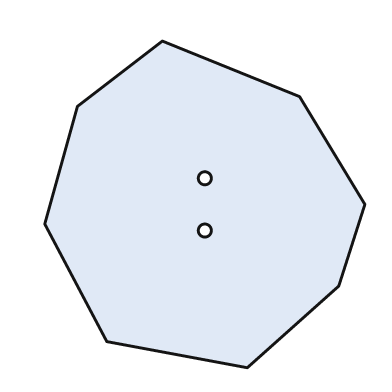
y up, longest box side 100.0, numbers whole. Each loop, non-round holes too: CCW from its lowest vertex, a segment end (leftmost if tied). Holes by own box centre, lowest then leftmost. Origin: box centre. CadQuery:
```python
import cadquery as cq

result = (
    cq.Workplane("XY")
    .moveTo(13.0, -50.0)
    .lineTo(41.0, -25.0)
    .lineTo(49.0, 0.0)
    .lineTo(29.0, 33.0)
    .lineTo(-13.0, 50.0)
    .lineTo(-39.0, 30.0)
    .lineTo(-49.0, -6.0)
    .lineTo(-30.0, -42.0)
    .close()
    .moveTo(0.0, -8.0)
    .circle(2.0)
    .moveTo(0.0, 8.0)
    .circle(2.0)
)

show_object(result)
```